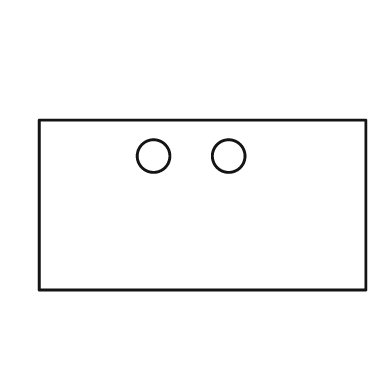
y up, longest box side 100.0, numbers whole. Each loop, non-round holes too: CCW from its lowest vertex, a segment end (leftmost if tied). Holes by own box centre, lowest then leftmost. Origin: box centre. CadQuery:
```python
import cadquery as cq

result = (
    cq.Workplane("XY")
    .moveTo(-50.0, -26.0)
    .lineTo(50.0, -26.0)
    .lineTo(50.0, 26.0)
    .lineTo(-50.0, 26.0)
    .close()
    .moveTo(-15.0, 15.0)
    .circle(5.0)
    .moveTo(8.0, 15.0)
    .circle(5.0)
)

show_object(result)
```